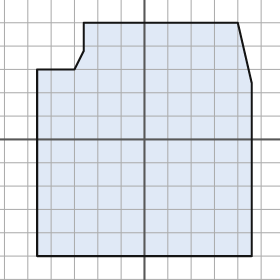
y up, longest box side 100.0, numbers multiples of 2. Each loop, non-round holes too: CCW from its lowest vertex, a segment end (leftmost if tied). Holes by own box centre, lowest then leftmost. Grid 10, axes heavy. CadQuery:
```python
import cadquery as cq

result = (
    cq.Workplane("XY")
    .moveTo(-46.0, -50.0)
    .lineTo(46.0, -50.0)
    .lineTo(46.0, 24.0)
    .lineTo(40.0, 50.0)
    .lineTo(-26.0, 50.0)
    .lineTo(-26.0, 38.0)
    .lineTo(-30.0, 30.0)
    .lineTo(-46.0, 30.0)
    .close()
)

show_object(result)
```